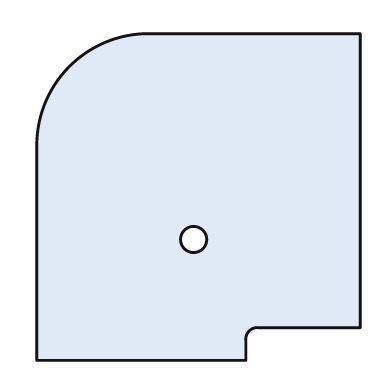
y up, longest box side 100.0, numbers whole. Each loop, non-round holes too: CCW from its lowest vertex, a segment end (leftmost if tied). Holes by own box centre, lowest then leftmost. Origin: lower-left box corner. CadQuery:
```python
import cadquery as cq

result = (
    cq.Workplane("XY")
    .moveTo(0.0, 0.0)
    .lineTo(64.0, 0.0)
    .lineTo(64.0, 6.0)
    .threePointArc((65.0, 9.0), (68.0, 10.0))
    .lineTo(99.0, 10.0)
    .lineTo(99.0, 100.0)
    .lineTo(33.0, 100.0)
    .threePointArc((10.0, 90.0), (0.0, 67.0))
    .close()
    .moveTo(48.0, 37.0)
    .circle(4.0)
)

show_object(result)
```